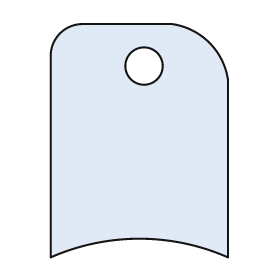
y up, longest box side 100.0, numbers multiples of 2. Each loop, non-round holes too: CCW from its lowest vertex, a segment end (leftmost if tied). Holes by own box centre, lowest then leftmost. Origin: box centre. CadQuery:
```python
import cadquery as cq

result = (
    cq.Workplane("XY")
    .moveTo(-38.0, -50.0)
    .threePointArc((0.0, -42.0), (38.0, -50.0))
    .lineTo(38.0, 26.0)
    .threePointArc((30.0, 42.0), (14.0, 50.0))
    .lineTo(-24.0, 50.0)
    .threePointArc((-34.0, 46.0), (-38.0, 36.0))
    .close()
    .moveTo(2.0, 32.0)
    .circle(8.0)
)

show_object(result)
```